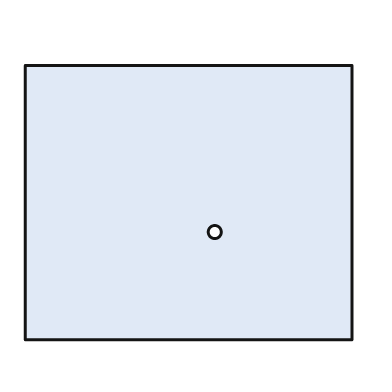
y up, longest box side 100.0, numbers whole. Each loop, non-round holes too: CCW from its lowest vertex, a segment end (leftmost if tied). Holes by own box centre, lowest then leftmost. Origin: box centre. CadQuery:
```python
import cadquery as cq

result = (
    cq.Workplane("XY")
    .moveTo(-50.0, -42.0)
    .lineTo(50.0, -42.0)
    .lineTo(50.0, 42.0)
    .lineTo(-50.0, 42.0)
    .close()
    .moveTo(8.0, -9.0)
    .circle(2.0)
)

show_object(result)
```